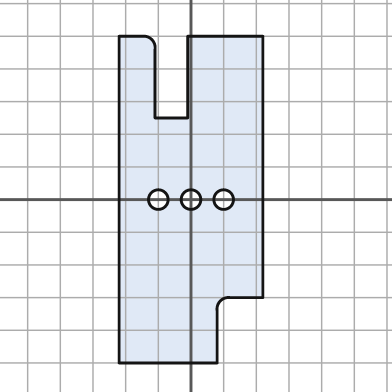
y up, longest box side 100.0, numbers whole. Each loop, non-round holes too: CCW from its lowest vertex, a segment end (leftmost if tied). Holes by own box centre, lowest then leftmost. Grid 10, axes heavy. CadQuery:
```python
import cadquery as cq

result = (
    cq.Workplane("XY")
    .moveTo(-22.0, -50.0)
    .lineTo(8.0, -50.0)
    .lineTo(8.0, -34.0)
    .threePointArc((9.0, -31.0), (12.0, -30.0))
    .lineTo(22.0, -30.0)
    .lineTo(22.0, 50.0)
    .lineTo(-1.0, 50.0)
    .lineTo(-1.0, 25.0)
    .lineTo(-11.0, 25.0)
    .lineTo(-11.0, 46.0)
    .threePointArc((-12.0, 49.0), (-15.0, 50.0))
    .lineTo(-22.0, 50.0)
    .close()
    .moveTo(-10.0, 0.0)
    .circle(3.0)
    .moveTo(0.0, 0.0)
    .circle(3.0)
    .moveTo(10.0, 0.0)
    .circle(3.0)
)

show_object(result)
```